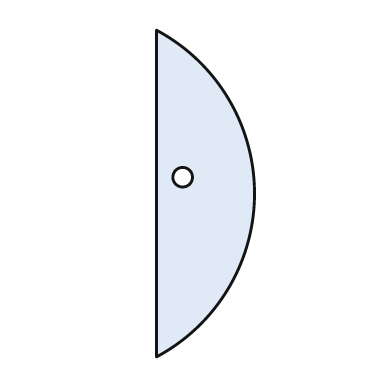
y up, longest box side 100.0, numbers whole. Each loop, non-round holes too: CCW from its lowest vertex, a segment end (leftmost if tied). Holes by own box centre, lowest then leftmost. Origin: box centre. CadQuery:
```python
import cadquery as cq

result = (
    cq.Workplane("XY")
    .moveTo(-15.0, -50.0)
    .threePointArc((15.0, 0.0), (-15.0, 50.0))
    .close()
    .moveTo(-7.0, 5.0)
    .circle(3.0)
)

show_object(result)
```